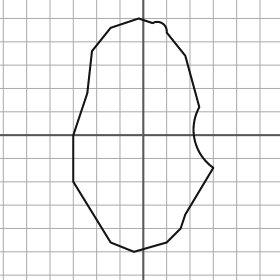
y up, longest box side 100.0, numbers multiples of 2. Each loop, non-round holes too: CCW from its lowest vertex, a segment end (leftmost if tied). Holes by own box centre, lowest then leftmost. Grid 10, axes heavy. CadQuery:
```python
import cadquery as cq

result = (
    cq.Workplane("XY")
    .moveTo(-4.0, -50.0)
    .lineTo(10.0, -46.0)
    .lineTo(16.0, -40.0)
    .lineTo(18.0, -34.0)
    .lineTo(30.0, -14.0)
    .threePointArc((22.0, -2.0), (24.0, 12.0))
    .lineTo(18.0, 34.0)
    .lineTo(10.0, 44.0)
    .threePointArc((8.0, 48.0), (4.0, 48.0))
    .lineTo(-2.0, 50.0)
    .lineTo(-14.0, 46.0)
    .lineTo(-22.0, 36.0)
    .lineTo(-24.0, 18.0)
    .lineTo(-30.0, 0.0)
    .lineTo(-30.0, -20.0)
    .lineTo(-14.0, -46.0)
    .close()
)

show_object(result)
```